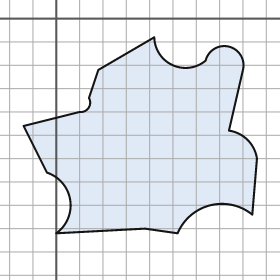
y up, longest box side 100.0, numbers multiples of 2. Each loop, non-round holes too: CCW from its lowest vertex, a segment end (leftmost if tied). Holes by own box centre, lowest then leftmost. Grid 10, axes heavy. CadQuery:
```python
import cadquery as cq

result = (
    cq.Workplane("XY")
    .moveTo(0.0, -92.0)
    .lineTo(38.0, -90.0)
    .lineTo(52.0, -92.0)
    .threePointArc((66.0, -80.0), (84.0, -84.0))
    .lineTo(86.0, -60.0)
    .threePointArc((82.0, -52.0), (74.0, -48.0))
    .lineTo(80.0, -22.0)
    .threePointArc((74.0, -12.0), (64.0, -18.0))
    .threePointArc((50.0, -20.0), (42.0, -8.0))
    .lineTo(18.0, -22.0)
    .lineTo(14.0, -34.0)
    .threePointArc((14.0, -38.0), (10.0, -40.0))
    .lineTo(-14.0, -46.0)
    .lineTo(-4.0, -66.0)
    .threePointArc((6.0, -78.0), (0.0, -92.0))
    .close()
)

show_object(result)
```